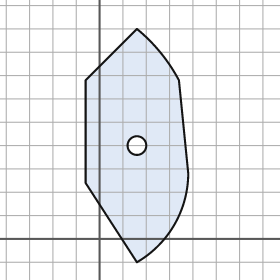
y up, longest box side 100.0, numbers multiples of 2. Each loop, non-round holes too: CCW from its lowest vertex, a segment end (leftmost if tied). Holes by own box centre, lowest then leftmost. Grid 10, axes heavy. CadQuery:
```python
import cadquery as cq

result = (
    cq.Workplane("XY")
    .moveTo(16.0, -10.0)
    .threePointArc((32.0, 6.0), (38.0, 28.0))
    .lineTo(34.0, 68.0)
    .threePointArc((26.0, 80.0), (16.0, 90.0))
    .lineTo(-6.0, 68.0)
    .lineTo(-6.0, 24.0)
    .close()
    .moveTo(16.0, 40.0)
    .circle(4.0)
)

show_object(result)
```